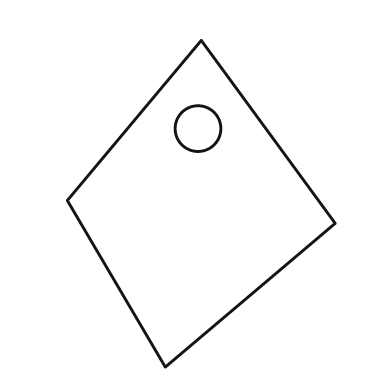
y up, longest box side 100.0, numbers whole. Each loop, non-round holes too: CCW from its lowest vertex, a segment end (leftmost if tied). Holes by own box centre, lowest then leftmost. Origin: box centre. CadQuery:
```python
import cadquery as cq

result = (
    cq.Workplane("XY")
    .moveTo(-11.0, -50.0)
    .lineTo(41.0, -6.0)
    .lineTo(0.0, 50.0)
    .lineTo(-41.0, 1.0)
    .close()
    .moveTo(-1.0, 23.0)
    .circle(7.0)
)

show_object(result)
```